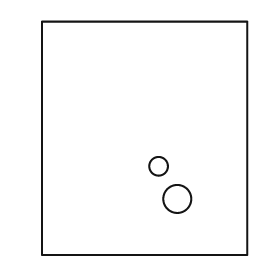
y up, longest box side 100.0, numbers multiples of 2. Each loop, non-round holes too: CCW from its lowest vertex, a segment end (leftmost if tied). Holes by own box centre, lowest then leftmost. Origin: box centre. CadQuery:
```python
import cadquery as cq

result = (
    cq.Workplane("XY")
    .moveTo(-44.0, -50.0)
    .lineTo(44.0, -50.0)
    .lineTo(44.0, 50.0)
    .lineTo(-44.0, 50.0)
    .close()
    .moveTo(14.0, -26.0)
    .circle(6.0)
    .moveTo(6.0, -12.0)
    .circle(4.0)
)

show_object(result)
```